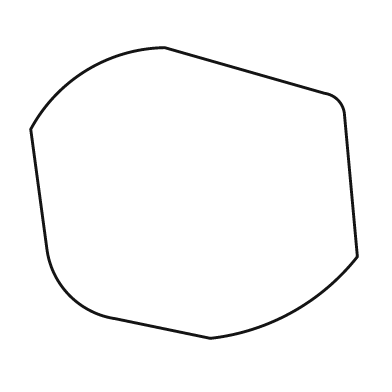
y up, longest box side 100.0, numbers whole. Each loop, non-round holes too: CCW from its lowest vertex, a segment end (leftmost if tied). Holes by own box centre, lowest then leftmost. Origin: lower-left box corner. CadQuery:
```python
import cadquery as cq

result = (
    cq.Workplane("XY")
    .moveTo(55.0, 0.0)
    .threePointArc((80.0, 8.0), (100.0, 25.0))
    .lineTo(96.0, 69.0)
    .threePointArc((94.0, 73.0), (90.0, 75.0))
    .lineTo(41.0, 89.0)
    .threePointArc((17.0, 82.0), (0.0, 64.0))
    .lineTo(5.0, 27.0)
    .threePointArc((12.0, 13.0), (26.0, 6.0))
    .close()
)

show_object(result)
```